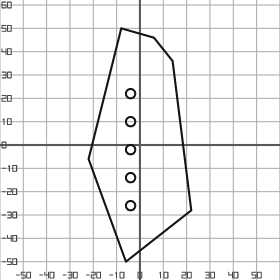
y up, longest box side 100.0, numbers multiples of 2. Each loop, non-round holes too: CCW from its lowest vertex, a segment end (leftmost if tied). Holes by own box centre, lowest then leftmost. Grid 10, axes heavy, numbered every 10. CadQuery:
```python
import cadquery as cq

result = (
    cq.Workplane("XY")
    .moveTo(-6.0, -50.0)
    .lineTo(22.0, -28.0)
    .lineTo(14.0, 36.0)
    .lineTo(6.0, 46.0)
    .lineTo(-8.0, 50.0)
    .lineTo(-22.0, -6.0)
    .close()
    .moveTo(-4.0, -26.0)
    .circle(2.0)
    .moveTo(-4.0, -14.0)
    .circle(2.0)
    .moveTo(-4.0, -2.0)
    .circle(2.0)
    .moveTo(-4.0, 10.0)
    .circle(2.0)
    .moveTo(-4.0, 22.0)
    .circle(2.0)
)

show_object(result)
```